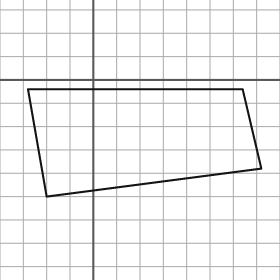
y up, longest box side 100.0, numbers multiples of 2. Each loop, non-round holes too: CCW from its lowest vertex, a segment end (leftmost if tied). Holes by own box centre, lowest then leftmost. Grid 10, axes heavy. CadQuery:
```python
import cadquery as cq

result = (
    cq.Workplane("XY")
    .moveTo(-20.0, -50.0)
    .lineTo(72.0, -38.0)
    .lineTo(64.0, -4.0)
    .lineTo(-28.0, -4.0)
    .close()
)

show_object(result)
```